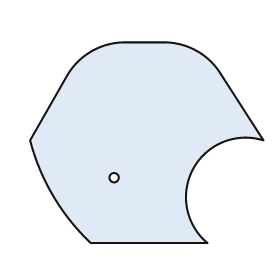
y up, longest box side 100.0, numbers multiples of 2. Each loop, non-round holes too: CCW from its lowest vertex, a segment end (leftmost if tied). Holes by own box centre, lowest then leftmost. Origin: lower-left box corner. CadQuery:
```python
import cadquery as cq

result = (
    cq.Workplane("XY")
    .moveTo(26.0, 0.0)
    .lineTo(76.0, 0.0)
    .threePointArc((70.0, 32.0), (100.0, 44.0))
    .lineTo(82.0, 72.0)
    .threePointArc((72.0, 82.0), (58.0, 86.0))
    .lineTo(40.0, 86.0)
    .threePointArc((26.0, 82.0), (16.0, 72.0))
    .lineTo(0.0, 44.0)
    .threePointArc((10.0, 20.0), (26.0, 0.0))
    .close()
    .moveTo(36.0, 28.0)
    .circle(2.0)
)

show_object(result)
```